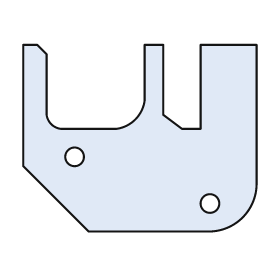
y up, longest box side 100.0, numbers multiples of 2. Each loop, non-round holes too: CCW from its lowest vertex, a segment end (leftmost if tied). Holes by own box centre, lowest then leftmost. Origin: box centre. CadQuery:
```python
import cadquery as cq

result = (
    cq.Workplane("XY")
    .moveTo(-22.0, -40.0)
    .lineTo(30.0, -40.0)
    .threePointArc((44.0, -34.0), (50.0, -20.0))
    .lineTo(50.0, 40.0)
    .lineTo(26.0, 40.0)
    .lineTo(26.0, 4.0)
    .lineTo(18.0, 4.0)
    .lineTo(10.0, 10.0)
    .lineTo(10.0, 40.0)
    .lineTo(2.0, 40.0)
    .lineTo(2.0, 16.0)
    .threePointArc((-2.0, 8.0), (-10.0, 4.0))
    .lineTo(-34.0, 4.0)
    .threePointArc((-38.0, 6.0), (-40.0, 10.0))
    .lineTo(-40.0, 36.0)
    .lineTo(-44.0, 40.0)
    .lineTo(-50.0, 40.0)
    .lineTo(-50.0, -12.0)
    .close()
    .moveTo(30.0, -28.0)
    .circle(4.0)
    .moveTo(-28.0, -8.0)
    .circle(4.0)
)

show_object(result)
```